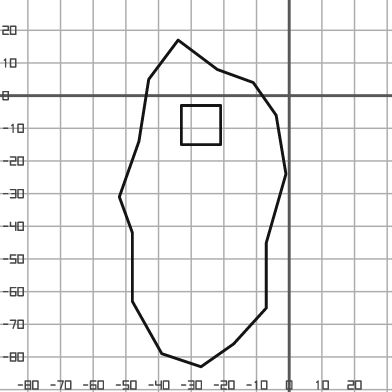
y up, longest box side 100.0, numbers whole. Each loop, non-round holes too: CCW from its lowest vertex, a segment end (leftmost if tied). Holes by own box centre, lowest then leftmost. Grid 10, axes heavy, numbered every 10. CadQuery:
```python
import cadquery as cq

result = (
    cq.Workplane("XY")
    .moveTo(-27.0, -83.0)
    .lineTo(-17.0, -76.0)
    .lineTo(-7.0, -65.0)
    .lineTo(-7.0, -45.0)
    .lineTo(-1.0, -24.0)
    .lineTo(-4.0, -6.0)
    .lineTo(-11.0, 4.0)
    .lineTo(-22.0, 8.0)
    .lineTo(-34.0, 17.0)
    .lineTo(-43.0, 5.0)
    .lineTo(-46.0, -14.0)
    .lineTo(-52.0, -31.0)
    .lineTo(-48.0, -42.0)
    .lineTo(-48.0, -63.0)
    .lineTo(-39.0, -79.0)
    .close()
    .moveTo(-33.0, -15.0)
    .lineTo(-21.0, -15.0)
    .lineTo(-21.0, -3.0)
    .lineTo(-33.0, -3.0)
    .close()
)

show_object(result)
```